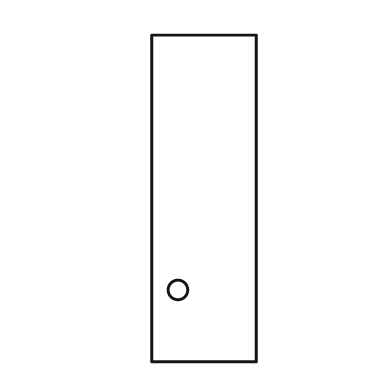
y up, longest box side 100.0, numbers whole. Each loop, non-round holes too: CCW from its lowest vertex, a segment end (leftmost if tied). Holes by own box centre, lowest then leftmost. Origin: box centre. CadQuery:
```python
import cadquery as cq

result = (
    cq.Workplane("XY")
    .moveTo(-16.0, -50.0)
    .lineTo(16.0, -50.0)
    .lineTo(16.0, 50.0)
    .lineTo(-16.0, 50.0)
    .close()
    .moveTo(-8.0, -28.0)
    .circle(3.0)
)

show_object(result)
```